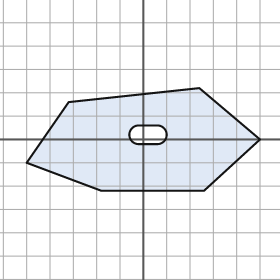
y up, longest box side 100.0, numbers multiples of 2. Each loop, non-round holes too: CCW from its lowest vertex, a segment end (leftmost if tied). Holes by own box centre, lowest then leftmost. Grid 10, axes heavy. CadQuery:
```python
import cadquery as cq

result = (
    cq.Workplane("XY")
    .moveTo(-18.0, -22.0)
    .lineTo(26.0, -22.0)
    .lineTo(50.0, 0.0)
    .lineTo(24.0, 22.0)
    .lineTo(-32.0, 16.0)
    .lineTo(-50.0, -10.0)
    .close()
    .moveTo(-2.0, -2.0)
    .lineTo(6.0, -2.0)
    .threePointArc((10.0, 2.0), (6.0, 6.0))
    .lineTo(-2.0, 6.0)
    .threePointArc((-6.0, 2.0), (-2.0, -2.0))
    .close()
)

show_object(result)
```